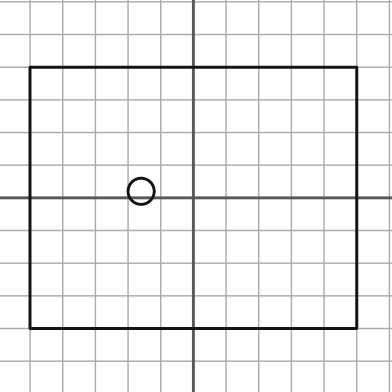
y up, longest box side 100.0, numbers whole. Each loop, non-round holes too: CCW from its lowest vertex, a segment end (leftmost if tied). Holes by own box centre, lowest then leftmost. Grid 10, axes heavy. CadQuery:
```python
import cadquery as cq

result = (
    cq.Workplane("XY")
    .moveTo(-50.0, -40.0)
    .lineTo(50.0, -40.0)
    .lineTo(50.0, 40.0)
    .lineTo(-50.0, 40.0)
    .close()
    .moveTo(-16.0, 2.0)
    .circle(4.0)
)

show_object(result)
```